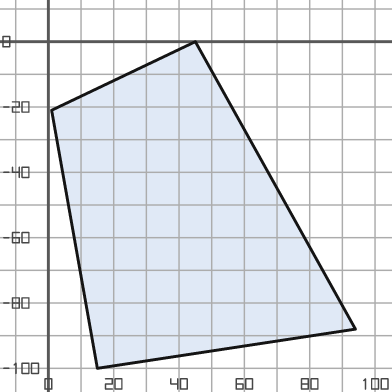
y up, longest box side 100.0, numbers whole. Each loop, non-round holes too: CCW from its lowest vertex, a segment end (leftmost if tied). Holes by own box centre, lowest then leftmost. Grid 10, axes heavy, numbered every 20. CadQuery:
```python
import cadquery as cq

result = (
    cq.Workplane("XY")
    .moveTo(15.0, -100.0)
    .lineTo(94.0, -88.0)
    .lineTo(45.0, 0.0)
    .lineTo(1.0, -21.0)
    .close()
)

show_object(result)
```